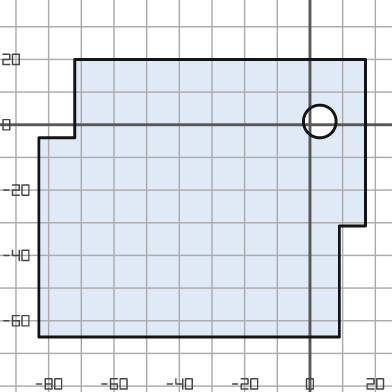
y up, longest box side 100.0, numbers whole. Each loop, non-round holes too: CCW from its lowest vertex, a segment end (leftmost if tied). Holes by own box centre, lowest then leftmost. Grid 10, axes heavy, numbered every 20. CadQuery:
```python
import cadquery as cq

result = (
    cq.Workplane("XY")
    .moveTo(-83.0, -65.0)
    .lineTo(9.0, -65.0)
    .lineTo(9.0, -31.0)
    .lineTo(17.0, -31.0)
    .lineTo(17.0, 20.0)
    .lineTo(-72.0, 20.0)
    .lineTo(-72.0, -4.0)
    .lineTo(-83.0, -4.0)
    .close()
    .moveTo(3.0, 1.0)
    .circle(5.0)
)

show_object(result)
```